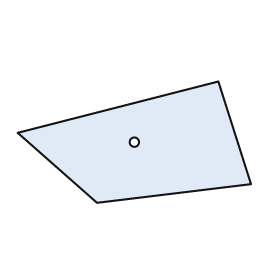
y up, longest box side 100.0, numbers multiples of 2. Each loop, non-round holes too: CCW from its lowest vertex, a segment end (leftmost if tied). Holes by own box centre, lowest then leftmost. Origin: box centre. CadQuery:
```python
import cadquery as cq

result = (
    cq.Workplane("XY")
    .moveTo(-16.0, -26.0)
    .lineTo(50.0, -18.0)
    .lineTo(36.0, 26.0)
    .lineTo(-50.0, 4.0)
    .close()
    .moveTo(0.0, 0.0)
    .circle(2.0)
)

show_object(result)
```